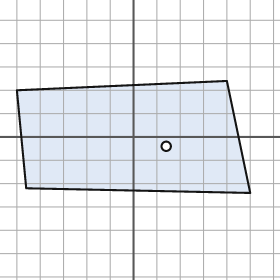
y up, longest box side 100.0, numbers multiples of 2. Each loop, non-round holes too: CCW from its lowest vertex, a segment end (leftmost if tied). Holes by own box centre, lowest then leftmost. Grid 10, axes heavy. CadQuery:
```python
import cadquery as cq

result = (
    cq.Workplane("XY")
    .moveTo(50.0, -24.0)
    .lineTo(40.0, 24.0)
    .lineTo(-50.0, 20.0)
    .lineTo(-46.0, -22.0)
    .close()
    .moveTo(14.0, -4.0)
    .circle(2.0)
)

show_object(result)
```